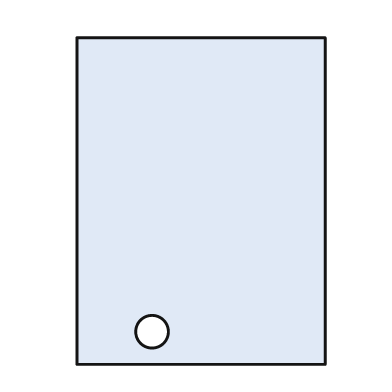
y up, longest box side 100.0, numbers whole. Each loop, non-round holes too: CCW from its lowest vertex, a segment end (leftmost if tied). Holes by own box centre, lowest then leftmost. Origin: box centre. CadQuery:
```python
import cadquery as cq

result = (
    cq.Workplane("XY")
    .moveTo(-38.0, -50.0)
    .lineTo(38.0, -50.0)
    .lineTo(38.0, 50.0)
    .lineTo(-38.0, 50.0)
    .close()
    .moveTo(-15.0, -40.0)
    .circle(5.0)
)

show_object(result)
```